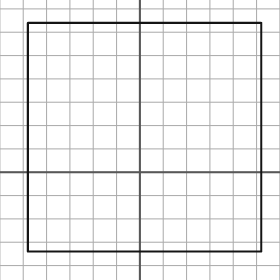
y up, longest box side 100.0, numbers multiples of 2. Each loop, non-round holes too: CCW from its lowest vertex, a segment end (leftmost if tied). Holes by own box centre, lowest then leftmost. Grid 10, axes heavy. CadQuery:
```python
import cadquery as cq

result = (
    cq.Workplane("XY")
    .moveTo(-48.0, -34.0)
    .lineTo(52.0, -34.0)
    .lineTo(52.0, 64.0)
    .lineTo(-48.0, 64.0)
    .close()
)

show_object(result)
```